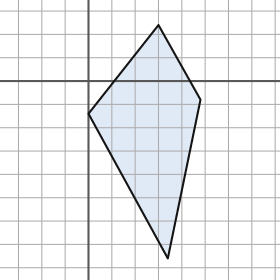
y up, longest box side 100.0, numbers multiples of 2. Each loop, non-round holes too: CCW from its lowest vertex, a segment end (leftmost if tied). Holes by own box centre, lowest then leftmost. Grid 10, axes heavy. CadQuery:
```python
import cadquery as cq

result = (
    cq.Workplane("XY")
    .moveTo(34.0, -76.0)
    .lineTo(48.0, -8.0)
    .lineTo(30.0, 24.0)
    .lineTo(0.0, -14.0)
    .close()
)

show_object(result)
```